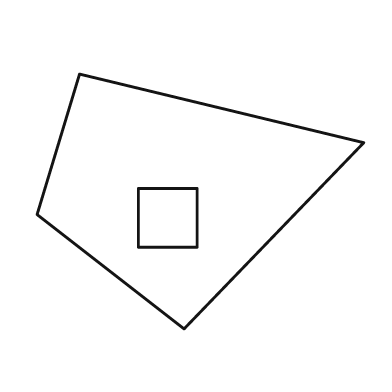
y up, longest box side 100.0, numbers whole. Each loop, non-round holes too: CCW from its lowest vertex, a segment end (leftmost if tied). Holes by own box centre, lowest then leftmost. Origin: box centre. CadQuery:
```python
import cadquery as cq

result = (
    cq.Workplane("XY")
    .moveTo(-5.0, -39.0)
    .lineTo(50.0, 18.0)
    .lineTo(-37.0, 39.0)
    .lineTo(-50.0, -4.0)
    .close()
    .moveTo(-19.0, -14.0)
    .lineTo(-1.0, -14.0)
    .lineTo(-1.0, 4.0)
    .lineTo(-19.0, 4.0)
    .close()
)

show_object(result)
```